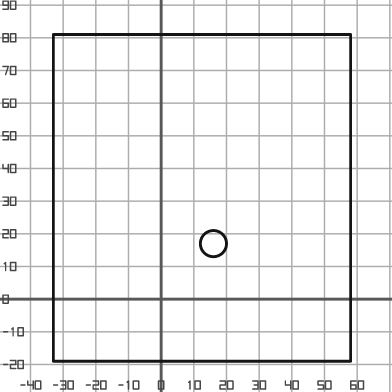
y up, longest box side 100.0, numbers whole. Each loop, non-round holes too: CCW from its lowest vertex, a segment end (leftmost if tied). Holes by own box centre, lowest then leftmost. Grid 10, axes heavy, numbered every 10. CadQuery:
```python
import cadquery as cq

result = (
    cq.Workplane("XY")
    .moveTo(-33.0, -19.0)
    .lineTo(58.0, -19.0)
    .lineTo(58.0, 81.0)
    .lineTo(-33.0, 81.0)
    .close()
    .moveTo(16.0, 17.0)
    .circle(4.0)
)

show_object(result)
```